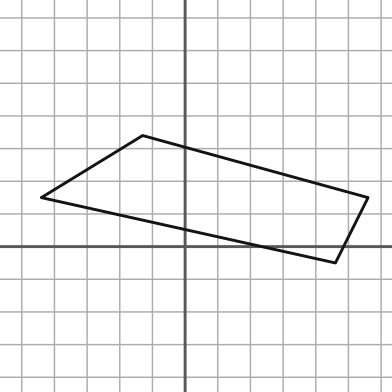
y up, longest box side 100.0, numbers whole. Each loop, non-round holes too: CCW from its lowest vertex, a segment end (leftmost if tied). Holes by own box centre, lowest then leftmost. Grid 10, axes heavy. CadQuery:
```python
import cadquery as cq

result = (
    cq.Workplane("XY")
    .moveTo(46.0, -5.0)
    .lineTo(56.0, 15.0)
    .lineTo(-13.0, 34.0)
    .lineTo(-44.0, 15.0)
    .close()
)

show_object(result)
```